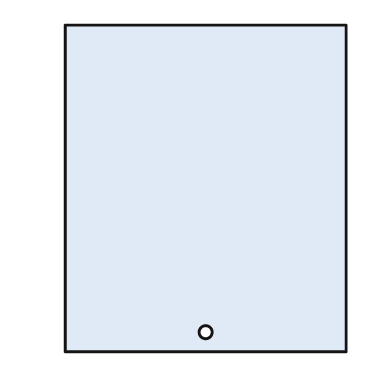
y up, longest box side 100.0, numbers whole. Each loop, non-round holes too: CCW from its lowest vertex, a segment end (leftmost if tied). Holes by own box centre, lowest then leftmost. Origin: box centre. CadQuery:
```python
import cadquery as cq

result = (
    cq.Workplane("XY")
    .moveTo(-43.0, -50.0)
    .lineTo(43.0, -50.0)
    .lineTo(43.0, 50.0)
    .lineTo(-43.0, 50.0)
    .close()
    .moveTo(0.0, -44.0)
    .circle(2.0)
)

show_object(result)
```